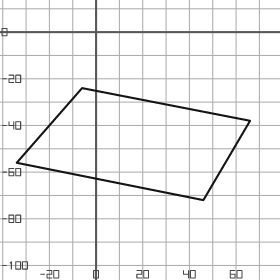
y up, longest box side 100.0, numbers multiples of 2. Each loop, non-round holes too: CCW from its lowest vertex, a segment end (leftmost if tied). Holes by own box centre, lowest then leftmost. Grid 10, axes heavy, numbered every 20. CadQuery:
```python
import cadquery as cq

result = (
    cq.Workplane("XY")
    .moveTo(46.0, -72.0)
    .lineTo(66.0, -38.0)
    .lineTo(-6.0, -24.0)
    .lineTo(-34.0, -56.0)
    .close()
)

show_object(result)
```